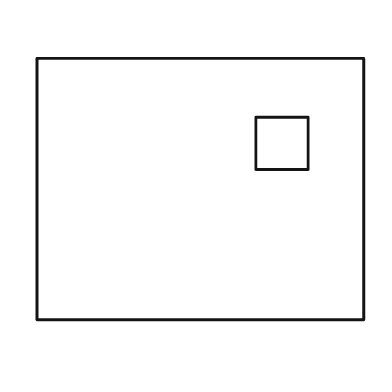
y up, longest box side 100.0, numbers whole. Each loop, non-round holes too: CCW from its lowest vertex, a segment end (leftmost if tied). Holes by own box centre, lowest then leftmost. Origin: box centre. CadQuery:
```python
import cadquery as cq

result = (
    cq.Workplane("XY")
    .moveTo(-50.0, -40.0)
    .lineTo(50.0, -40.0)
    .lineTo(50.0, 40.0)
    .lineTo(-50.0, 40.0)
    .close()
    .moveTo(17.0, 6.0)
    .lineTo(33.0, 6.0)
    .lineTo(33.0, 22.0)
    .lineTo(17.0, 22.0)
    .close()
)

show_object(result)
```